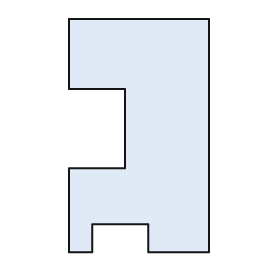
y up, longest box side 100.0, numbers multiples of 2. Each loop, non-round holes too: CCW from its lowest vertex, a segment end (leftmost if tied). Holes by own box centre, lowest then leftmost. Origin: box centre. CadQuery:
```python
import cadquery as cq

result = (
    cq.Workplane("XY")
    .moveTo(-30.0, -50.0)
    .lineTo(-20.0, -50.0)
    .lineTo(-20.0, -38.0)
    .lineTo(4.0, -38.0)
    .lineTo(4.0, -50.0)
    .lineTo(30.0, -50.0)
    .lineTo(30.0, 50.0)
    .lineTo(-30.0, 50.0)
    .lineTo(-30.0, 20.0)
    .lineTo(-6.0, 20.0)
    .lineTo(-6.0, -14.0)
    .lineTo(-30.0, -14.0)
    .close()
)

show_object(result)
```